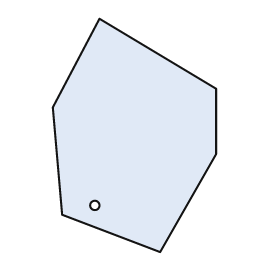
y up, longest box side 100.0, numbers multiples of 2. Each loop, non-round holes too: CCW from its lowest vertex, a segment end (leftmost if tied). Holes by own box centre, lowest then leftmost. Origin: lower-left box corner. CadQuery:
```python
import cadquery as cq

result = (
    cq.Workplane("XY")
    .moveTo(46.0, 0.0)
    .lineTo(70.0, 42.0)
    .lineTo(70.0, 70.0)
    .lineTo(20.0, 100.0)
    .lineTo(0.0, 62.0)
    .lineTo(4.0, 16.0)
    .close()
    .moveTo(18.0, 20.0)
    .circle(2.0)
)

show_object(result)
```